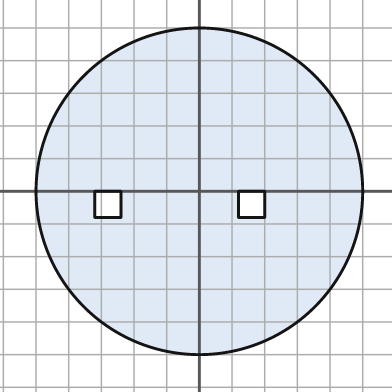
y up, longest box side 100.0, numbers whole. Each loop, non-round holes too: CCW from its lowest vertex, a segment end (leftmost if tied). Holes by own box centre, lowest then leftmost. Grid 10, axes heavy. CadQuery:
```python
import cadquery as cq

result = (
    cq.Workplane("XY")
    .moveTo(0.0, 0.0)
    .circle(50.0)
    .moveTo(-32.0, -8.0)
    .lineTo(-24.0, -8.0)
    .lineTo(-24.0, 0.0)
    .lineTo(-32.0, 0.0)
    .close()
    .moveTo(12.0, -8.0)
    .lineTo(20.0, -8.0)
    .lineTo(20.0, 0.0)
    .lineTo(12.0, 0.0)
    .close()
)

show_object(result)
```